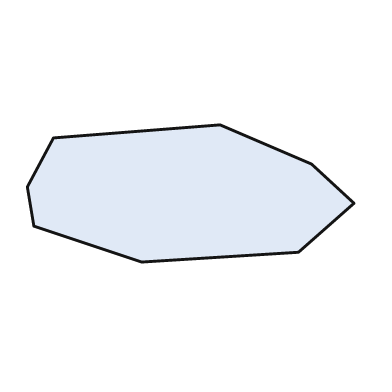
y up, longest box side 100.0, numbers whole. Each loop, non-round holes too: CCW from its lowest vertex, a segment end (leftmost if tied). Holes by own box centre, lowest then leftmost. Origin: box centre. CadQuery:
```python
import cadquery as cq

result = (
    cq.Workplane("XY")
    .moveTo(-15.0, -21.0)
    .lineTo(33.0, -18.0)
    .lineTo(50.0, -3.0)
    .lineTo(37.0, 9.0)
    .lineTo(9.0, 21.0)
    .lineTo(-42.0, 17.0)
    .lineTo(-50.0, 2.0)
    .lineTo(-48.0, -10.0)
    .close()
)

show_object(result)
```